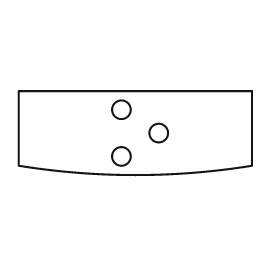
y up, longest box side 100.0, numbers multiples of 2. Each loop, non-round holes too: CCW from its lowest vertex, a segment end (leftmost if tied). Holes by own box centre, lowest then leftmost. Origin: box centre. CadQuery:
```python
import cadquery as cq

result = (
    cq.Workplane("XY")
    .moveTo(-50.0, -14.0)
    .threePointArc((0.0, -18.0), (50.0, -14.0))
    .lineTo(50.0, 18.0)
    .lineTo(-50.0, 18.0)
    .close()
    .moveTo(-6.0, -10.0)
    .circle(4.0)
    .moveTo(10.0, 0.0)
    .circle(4.0)
    .moveTo(-6.0, 10.0)
    .circle(4.0)
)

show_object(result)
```